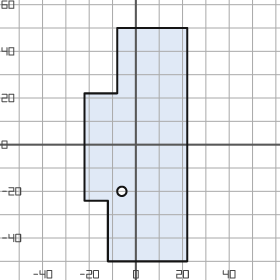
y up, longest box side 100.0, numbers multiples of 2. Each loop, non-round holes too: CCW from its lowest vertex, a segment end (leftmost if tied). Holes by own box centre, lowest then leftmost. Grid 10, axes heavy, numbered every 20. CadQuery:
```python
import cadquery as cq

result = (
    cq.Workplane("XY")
    .moveTo(-12.0, -50.0)
    .lineTo(22.0, -50.0)
    .lineTo(22.0, 50.0)
    .lineTo(-8.0, 50.0)
    .lineTo(-8.0, 22.0)
    .lineTo(-22.0, 22.0)
    .lineTo(-22.0, -24.0)
    .lineTo(-12.0, -24.0)
    .close()
    .moveTo(-6.0, -20.0)
    .circle(2.0)
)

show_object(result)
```